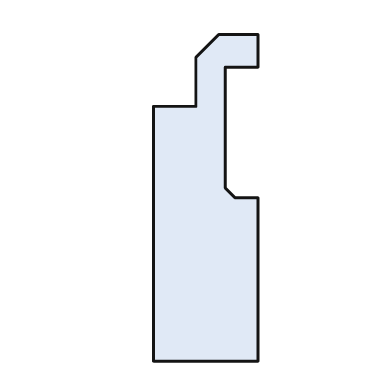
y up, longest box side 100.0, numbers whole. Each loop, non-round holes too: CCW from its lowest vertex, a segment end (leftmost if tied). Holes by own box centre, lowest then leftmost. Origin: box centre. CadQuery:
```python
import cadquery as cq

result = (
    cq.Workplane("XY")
    .moveTo(-16.0, -50.0)
    .lineTo(16.0, -50.0)
    .lineTo(16.0, 0.0)
    .lineTo(9.0, 0.0)
    .lineTo(6.0, 3.0)
    .lineTo(6.0, 40.0)
    .lineTo(16.0, 40.0)
    .lineTo(16.0, 50.0)
    .lineTo(4.0, 50.0)
    .lineTo(-3.0, 43.0)
    .lineTo(-3.0, 28.0)
    .lineTo(-16.0, 28.0)
    .close()
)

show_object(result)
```